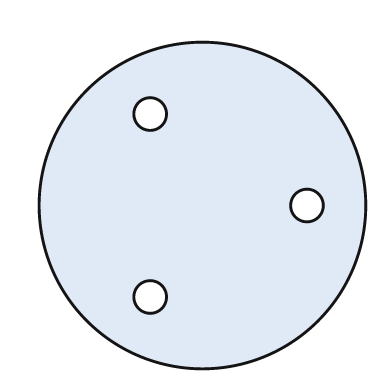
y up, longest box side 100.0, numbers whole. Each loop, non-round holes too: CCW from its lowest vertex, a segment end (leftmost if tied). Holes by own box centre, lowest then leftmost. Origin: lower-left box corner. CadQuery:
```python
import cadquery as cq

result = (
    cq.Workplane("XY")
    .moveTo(50.0, 50.0)
    .circle(50.0)
    .moveTo(34.0, 22.0)
    .circle(5.0)
    .moveTo(82.0, 50.0)
    .circle(5.0)
    .moveTo(34.0, 78.0)
    .circle(5.0)
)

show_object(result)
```